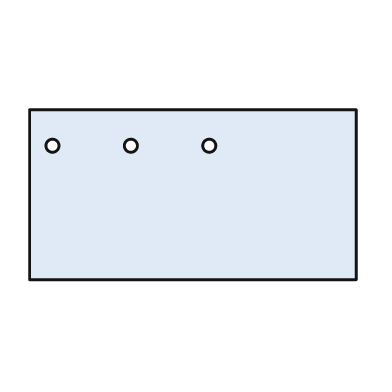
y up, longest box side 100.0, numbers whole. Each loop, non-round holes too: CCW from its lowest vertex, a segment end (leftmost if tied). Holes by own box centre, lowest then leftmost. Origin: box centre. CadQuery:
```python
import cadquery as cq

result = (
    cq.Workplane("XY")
    .moveTo(-50.0, -26.0)
    .lineTo(50.0, -26.0)
    .lineTo(50.0, 26.0)
    .lineTo(-50.0, 26.0)
    .close()
    .moveTo(-43.0, 15.0)
    .circle(2.0)
    .moveTo(-19.0, 15.0)
    .circle(2.0)
    .moveTo(5.0, 15.0)
    .circle(2.0)
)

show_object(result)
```